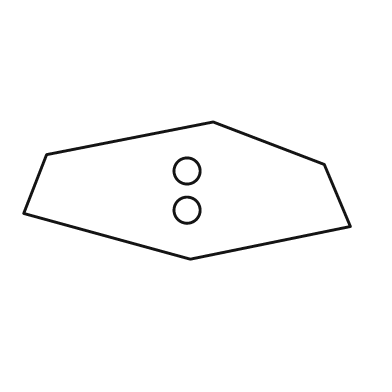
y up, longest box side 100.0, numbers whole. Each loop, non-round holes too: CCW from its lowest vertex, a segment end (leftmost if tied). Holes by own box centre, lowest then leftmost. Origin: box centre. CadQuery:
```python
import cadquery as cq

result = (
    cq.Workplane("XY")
    .moveTo(1.0, -21.0)
    .lineTo(50.0, -11.0)
    .lineTo(42.0, 8.0)
    .lineTo(8.0, 21.0)
    .lineTo(-43.0, 11.0)
    .lineTo(-50.0, -7.0)
    .close()
    .moveTo(0.0, -6.0)
    .circle(4.0)
    .moveTo(0.0, 6.0)
    .circle(4.0)
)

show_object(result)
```